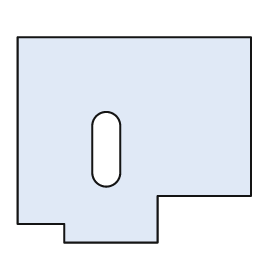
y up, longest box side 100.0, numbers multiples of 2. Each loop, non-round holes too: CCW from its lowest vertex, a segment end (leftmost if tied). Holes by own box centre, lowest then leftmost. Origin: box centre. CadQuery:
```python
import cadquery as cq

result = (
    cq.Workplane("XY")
    .moveTo(-30.0, -44.0)
    .lineTo(10.0, -44.0)
    .lineTo(10.0, -24.0)
    .lineTo(50.0, -24.0)
    .lineTo(50.0, 44.0)
    .lineTo(-50.0, 44.0)
    .lineTo(-50.0, -36.0)
    .lineTo(-30.0, -36.0)
    .close()
    .moveTo(-18.0, -14.0)
    .threePointArc((-12.0, -20.0), (-6.0, -14.0))
    .lineTo(-6.0, 6.0)
    .threePointArc((-12.0, 12.0), (-18.0, 6.0))
    .close()
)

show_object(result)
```